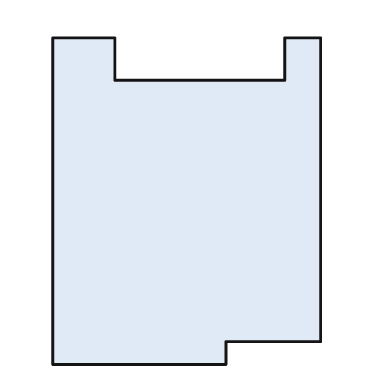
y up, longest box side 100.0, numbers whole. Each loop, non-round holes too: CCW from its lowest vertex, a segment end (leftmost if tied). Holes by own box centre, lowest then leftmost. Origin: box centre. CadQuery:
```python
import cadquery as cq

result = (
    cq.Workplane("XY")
    .moveTo(-41.0, -50.0)
    .lineTo(12.0, -50.0)
    .lineTo(12.0, -43.0)
    .lineTo(41.0, -43.0)
    .lineTo(41.0, 50.0)
    .lineTo(30.0, 50.0)
    .lineTo(30.0, 37.0)
    .lineTo(-22.0, 37.0)
    .lineTo(-22.0, 50.0)
    .lineTo(-41.0, 50.0)
    .close()
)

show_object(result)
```